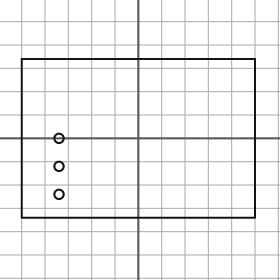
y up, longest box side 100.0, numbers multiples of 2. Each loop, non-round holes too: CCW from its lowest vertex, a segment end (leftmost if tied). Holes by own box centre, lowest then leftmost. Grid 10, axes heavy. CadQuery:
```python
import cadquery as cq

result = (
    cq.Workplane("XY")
    .moveTo(-50.0, -34.0)
    .lineTo(50.0, -34.0)
    .lineTo(50.0, 34.0)
    .lineTo(-50.0, 34.0)
    .close()
    .moveTo(-34.0, -24.0)
    .circle(2.0)
    .moveTo(-34.0, -12.0)
    .circle(2.0)
    .moveTo(-34.0, 0.0)
    .circle(2.0)
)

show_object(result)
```